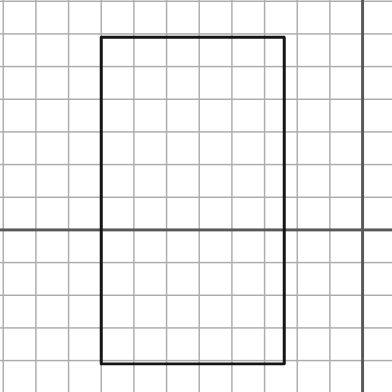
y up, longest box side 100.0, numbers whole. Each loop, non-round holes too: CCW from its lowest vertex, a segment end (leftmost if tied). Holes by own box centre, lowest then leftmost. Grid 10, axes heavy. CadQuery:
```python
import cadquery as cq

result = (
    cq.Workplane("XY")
    .moveTo(-80.0, -41.0)
    .lineTo(-24.0, -41.0)
    .lineTo(-24.0, 59.0)
    .lineTo(-80.0, 59.0)
    .close()
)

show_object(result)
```